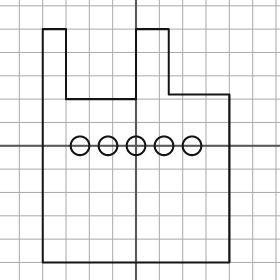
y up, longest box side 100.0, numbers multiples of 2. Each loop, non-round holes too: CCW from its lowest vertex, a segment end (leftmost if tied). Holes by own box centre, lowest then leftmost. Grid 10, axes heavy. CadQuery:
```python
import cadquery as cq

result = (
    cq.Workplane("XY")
    .moveTo(-40.0, -50.0)
    .lineTo(40.0, -50.0)
    .lineTo(40.0, 22.0)
    .lineTo(14.0, 22.0)
    .lineTo(14.0, 50.0)
    .lineTo(0.0, 50.0)
    .lineTo(0.0, 20.0)
    .lineTo(-30.0, 20.0)
    .lineTo(-30.0, 50.0)
    .lineTo(-40.0, 50.0)
    .close()
    .moveTo(-24.0, 0.0)
    .circle(4.0)
    .moveTo(-12.0, 0.0)
    .circle(4.0)
    .moveTo(0.0, 0.0)
    .circle(4.0)
    .moveTo(12.0, 0.0)
    .circle(4.0)
    .moveTo(24.0, 0.0)
    .circle(4.0)
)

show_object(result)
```